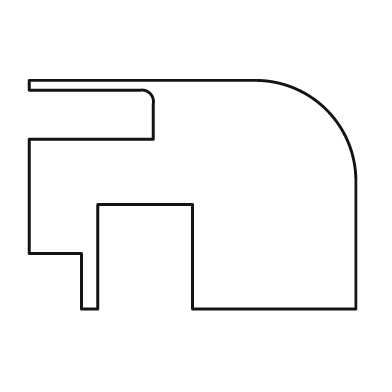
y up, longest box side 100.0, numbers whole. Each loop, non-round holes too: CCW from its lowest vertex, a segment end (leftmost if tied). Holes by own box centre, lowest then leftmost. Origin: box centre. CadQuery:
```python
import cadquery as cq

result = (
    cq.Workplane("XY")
    .moveTo(-34.0, -35.0)
    .lineTo(-29.0, -35.0)
    .lineTo(-29.0, -3.0)
    .lineTo(0.0, -3.0)
    .lineTo(0.0, -35.0)
    .lineTo(50.0, -35.0)
    .lineTo(50.0, 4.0)
    .threePointArc((41.0, 26.0), (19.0, 35.0))
    .lineTo(-50.0, 35.0)
    .lineTo(-50.0, 32.0)
    .lineTo(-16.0, 32.0)
    .threePointArc((-13.0, 31.0), (-12.0, 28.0))
    .lineTo(-12.0, 17.0)
    .lineTo(-50.0, 17.0)
    .lineTo(-50.0, -18.0)
    .lineTo(-34.0, -18.0)
    .close()
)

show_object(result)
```